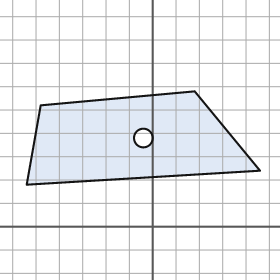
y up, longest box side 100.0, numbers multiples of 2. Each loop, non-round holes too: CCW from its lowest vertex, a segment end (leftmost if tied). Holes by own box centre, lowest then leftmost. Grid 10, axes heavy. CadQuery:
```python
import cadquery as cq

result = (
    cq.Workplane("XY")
    .moveTo(-54.0, 18.0)
    .lineTo(46.0, 24.0)
    .lineTo(18.0, 58.0)
    .lineTo(-48.0, 52.0)
    .close()
    .moveTo(-4.0, 38.0)
    .circle(4.0)
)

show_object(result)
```